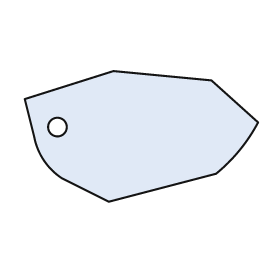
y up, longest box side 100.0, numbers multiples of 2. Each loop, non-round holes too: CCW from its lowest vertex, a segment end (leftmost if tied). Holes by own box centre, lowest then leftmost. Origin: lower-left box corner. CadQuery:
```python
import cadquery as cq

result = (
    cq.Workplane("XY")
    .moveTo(36.0, 0.0)
    .lineTo(82.0, 12.0)
    .threePointArc((92.0, 22.0), (100.0, 34.0))
    .lineTo(80.0, 52.0)
    .lineTo(38.0, 56.0)
    .lineTo(0.0, 44.0)
    .lineTo(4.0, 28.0)
    .threePointArc((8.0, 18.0), (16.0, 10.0))
    .close()
    .moveTo(14.0, 32.0)
    .circle(4.0)
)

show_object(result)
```